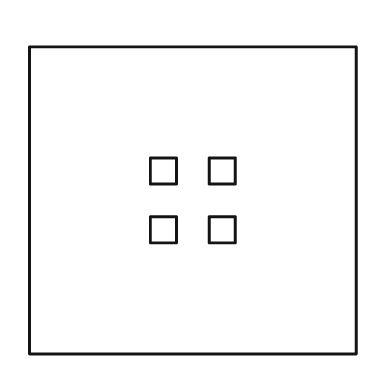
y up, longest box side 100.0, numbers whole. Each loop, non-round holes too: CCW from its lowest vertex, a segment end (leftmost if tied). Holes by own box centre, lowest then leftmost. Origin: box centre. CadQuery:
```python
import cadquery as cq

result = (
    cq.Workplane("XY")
    .moveTo(-50.0, -47.0)
    .lineTo(50.0, -47.0)
    .lineTo(50.0, 47.0)
    .lineTo(-50.0, 47.0)
    .close()
    .moveTo(-13.0, -13.0)
    .lineTo(-5.0, -13.0)
    .lineTo(-5.0, -5.0)
    .lineTo(-13.0, -5.0)
    .close()
    .moveTo(5.0, -13.0)
    .lineTo(13.0, -13.0)
    .lineTo(13.0, -5.0)
    .lineTo(5.0, -5.0)
    .close()
    .moveTo(-13.0, 5.0)
    .lineTo(-5.0, 5.0)
    .lineTo(-5.0, 13.0)
    .lineTo(-13.0, 13.0)
    .close()
    .moveTo(5.0, 5.0)
    .lineTo(13.0, 5.0)
    .lineTo(13.0, 13.0)
    .lineTo(5.0, 13.0)
    .close()
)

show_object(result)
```